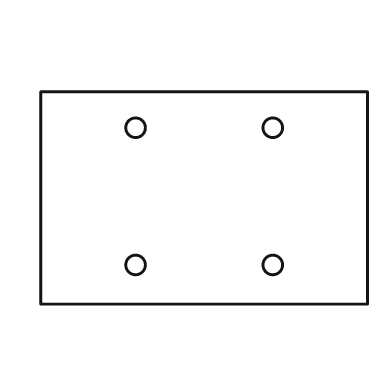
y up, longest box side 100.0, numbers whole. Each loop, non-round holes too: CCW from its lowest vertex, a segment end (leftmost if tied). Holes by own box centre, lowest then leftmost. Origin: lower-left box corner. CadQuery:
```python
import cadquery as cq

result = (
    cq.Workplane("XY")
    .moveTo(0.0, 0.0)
    .lineTo(100.0, 0.0)
    .lineTo(100.0, 65.0)
    .lineTo(0.0, 65.0)
    .close()
    .moveTo(29.0, 12.0)
    .circle(3.0)
    .moveTo(71.0, 12.0)
    .circle(3.0)
    .moveTo(29.0, 54.0)
    .circle(3.0)
    .moveTo(71.0, 54.0)
    .circle(3.0)
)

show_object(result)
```